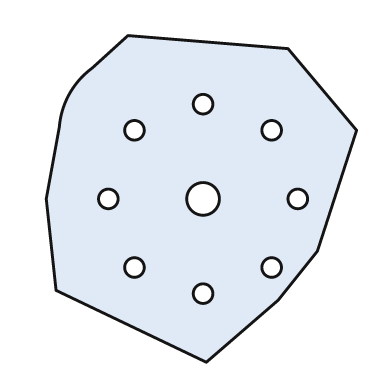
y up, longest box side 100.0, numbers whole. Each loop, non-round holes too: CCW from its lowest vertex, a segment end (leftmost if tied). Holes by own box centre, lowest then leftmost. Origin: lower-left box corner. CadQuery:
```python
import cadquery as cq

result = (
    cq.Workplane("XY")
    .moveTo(49.0, 0.0)
    .lineTo(71.0, 19.0)
    .lineTo(83.0, 34.0)
    .lineTo(95.0, 71.0)
    .lineTo(74.0, 96.0)
    .lineTo(25.0, 100.0)
    .lineTo(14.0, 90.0)
    .threePointArc((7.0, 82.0), (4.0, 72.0))
    .lineTo(0.0, 50.0)
    .lineTo(3.0, 22.0)
    .close()
    .moveTo(48.0, 21.0)
    .circle(3.0)
    .moveTo(27.0, 29.0)
    .circle(3.0)
    .moveTo(69.0, 29.0)
    .circle(3.0)
    .moveTo(19.0, 50.0)
    .circle(3.0)
    .moveTo(48.0, 50.0)
    .circle(5.0)
    .moveTo(77.0, 50.0)
    .circle(3.0)
    .moveTo(27.0, 71.0)
    .circle(3.0)
    .moveTo(69.0, 71.0)
    .circle(3.0)
    .moveTo(48.0, 79.0)
    .circle(3.0)
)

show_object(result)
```